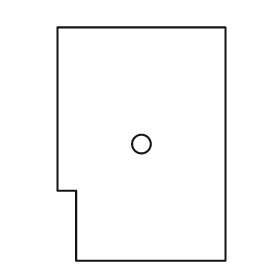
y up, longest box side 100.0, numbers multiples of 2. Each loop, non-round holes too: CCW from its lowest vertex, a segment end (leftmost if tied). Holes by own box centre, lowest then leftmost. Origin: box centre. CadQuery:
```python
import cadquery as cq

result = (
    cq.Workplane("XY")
    .moveTo(-28.0, -50.0)
    .lineTo(36.0, -50.0)
    .lineTo(36.0, 50.0)
    .lineTo(-36.0, 50.0)
    .lineTo(-36.0, -20.0)
    .lineTo(-28.0, -20.0)
    .close()
    .moveTo(0.0, 0.0)
    .circle(4.0)
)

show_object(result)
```